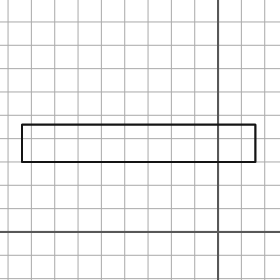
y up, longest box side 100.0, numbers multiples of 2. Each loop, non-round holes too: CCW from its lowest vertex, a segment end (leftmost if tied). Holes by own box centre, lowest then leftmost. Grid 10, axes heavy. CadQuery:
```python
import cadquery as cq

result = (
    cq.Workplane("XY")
    .moveTo(-84.0, 30.0)
    .lineTo(16.0, 30.0)
    .lineTo(16.0, 46.0)
    .lineTo(-84.0, 46.0)
    .close()
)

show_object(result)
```